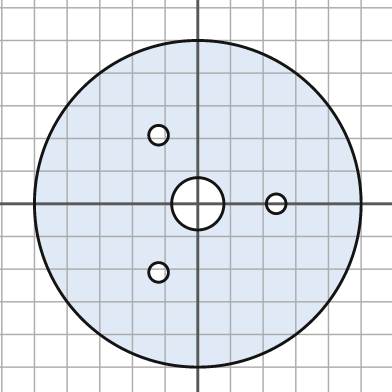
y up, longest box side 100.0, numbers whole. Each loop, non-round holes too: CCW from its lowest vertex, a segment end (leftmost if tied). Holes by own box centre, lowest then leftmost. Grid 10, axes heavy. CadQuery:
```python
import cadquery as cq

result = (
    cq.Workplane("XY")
    .moveTo(0.0, 0.0)
    .circle(50.0)
    .moveTo(-12.0, -21.0)
    .circle(3.0)
    .moveTo(0.0, 0.0)
    .circle(8.0)
    .moveTo(24.0, 0.0)
    .circle(3.0)
    .moveTo(-12.0, 21.0)
    .circle(3.0)
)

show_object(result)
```